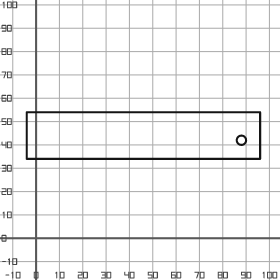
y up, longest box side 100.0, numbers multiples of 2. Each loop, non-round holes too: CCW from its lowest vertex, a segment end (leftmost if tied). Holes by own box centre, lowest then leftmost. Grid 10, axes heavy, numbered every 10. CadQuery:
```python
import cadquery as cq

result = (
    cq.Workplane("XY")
    .moveTo(-4.0, 34.0)
    .lineTo(96.0, 34.0)
    .lineTo(96.0, 54.0)
    .lineTo(-4.0, 54.0)
    .close()
    .moveTo(88.0, 42.0)
    .circle(2.0)
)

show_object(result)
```